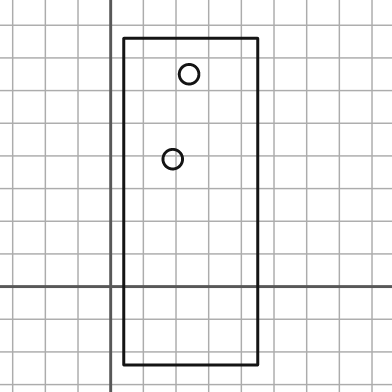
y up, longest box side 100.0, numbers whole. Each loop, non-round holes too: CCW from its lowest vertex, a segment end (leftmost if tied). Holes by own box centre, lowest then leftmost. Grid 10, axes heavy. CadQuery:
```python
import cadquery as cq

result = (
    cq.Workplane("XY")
    .moveTo(4.0, -24.0)
    .lineTo(45.0, -24.0)
    .lineTo(45.0, 76.0)
    .lineTo(4.0, 76.0)
    .close()
    .moveTo(19.0, 39.0)
    .circle(3.0)
    .moveTo(24.0, 65.0)
    .circle(3.0)
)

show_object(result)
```